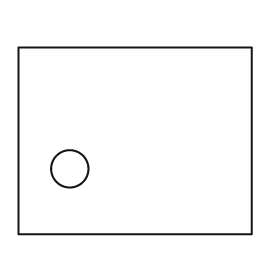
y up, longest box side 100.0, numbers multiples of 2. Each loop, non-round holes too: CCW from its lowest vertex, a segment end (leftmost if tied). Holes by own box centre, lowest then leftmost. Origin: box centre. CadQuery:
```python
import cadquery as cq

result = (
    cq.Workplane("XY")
    .moveTo(-50.0, -40.0)
    .lineTo(50.0, -40.0)
    .lineTo(50.0, 40.0)
    .lineTo(-50.0, 40.0)
    .close()
    .moveTo(-28.0, -12.0)
    .circle(8.0)
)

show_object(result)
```